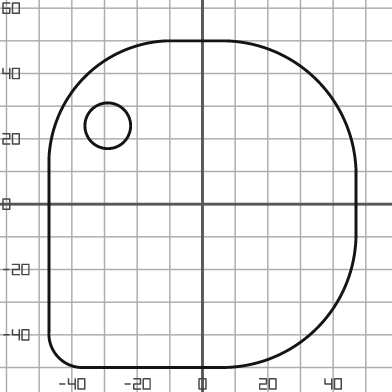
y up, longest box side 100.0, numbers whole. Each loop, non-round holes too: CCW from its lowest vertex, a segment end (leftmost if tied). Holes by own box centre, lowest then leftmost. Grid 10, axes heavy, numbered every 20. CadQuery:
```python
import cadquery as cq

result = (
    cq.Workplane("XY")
    .moveTo(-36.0, -50.0)
    .lineTo(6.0, -50.0)
    .threePointArc((35.0, -38.0), (47.0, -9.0))
    .lineTo(47.0, 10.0)
    .threePointArc((35.0, 38.0), (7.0, 50.0))
    .lineTo(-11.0, 50.0)
    .threePointArc((-36.0, 39.0), (-47.0, 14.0))
    .lineTo(-47.0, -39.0)
    .threePointArc((-44.0, -47.0), (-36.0, -50.0))
    .close()
    .moveTo(-29.0, 24.0)
    .circle(7.0)
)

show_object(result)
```